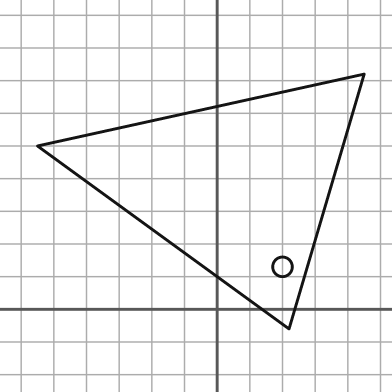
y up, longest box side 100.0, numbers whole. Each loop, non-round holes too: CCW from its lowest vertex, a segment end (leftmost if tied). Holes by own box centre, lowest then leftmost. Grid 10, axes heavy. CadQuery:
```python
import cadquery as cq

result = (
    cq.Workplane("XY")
    .moveTo(22.0, -6.0)
    .lineTo(45.0, 72.0)
    .lineTo(-55.0, 50.0)
    .close()
    .moveTo(20.0, 13.0)
    .circle(3.0)
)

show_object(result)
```